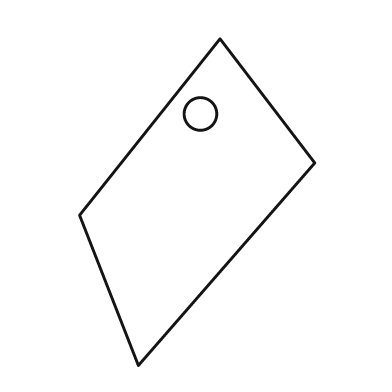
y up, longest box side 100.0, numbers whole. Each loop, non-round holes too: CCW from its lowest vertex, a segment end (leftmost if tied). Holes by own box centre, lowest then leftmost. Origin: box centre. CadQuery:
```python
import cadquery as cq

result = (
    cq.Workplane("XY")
    .moveTo(-18.0, -50.0)
    .lineTo(36.0, 12.0)
    .lineTo(7.0, 50.0)
    .lineTo(-36.0, -4.0)
    .close()
    .moveTo(1.0, 27.0)
    .circle(5.0)
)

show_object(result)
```